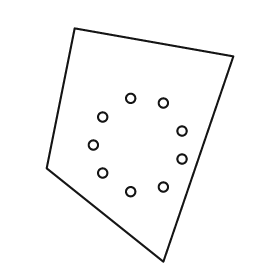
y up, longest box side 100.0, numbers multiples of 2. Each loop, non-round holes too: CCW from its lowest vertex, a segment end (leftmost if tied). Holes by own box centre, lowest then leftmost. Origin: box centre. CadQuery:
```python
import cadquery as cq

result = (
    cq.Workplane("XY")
    .moveTo(10.0, -50.0)
    .lineTo(40.0, 38.0)
    .lineTo(-28.0, 50.0)
    .lineTo(-40.0, -10.0)
    .close()
    .moveTo(-4.0, -20.0)
    .circle(2.0)
    .moveTo(10.0, -18.0)
    .circle(2.0)
    .moveTo(-16.0, -12.0)
    .circle(2.0)
    .moveTo(18.0, -6.0)
    .circle(2.0)
    .moveTo(-20.0, 0.0)
    .circle(2.0)
    .moveTo(18.0, 6.0)
    .circle(2.0)
    .moveTo(-16.0, 12.0)
    .circle(2.0)
    .moveTo(10.0, 18.0)
    .circle(2.0)
    .moveTo(-4.0, 20.0)
    .circle(2.0)
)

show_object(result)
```